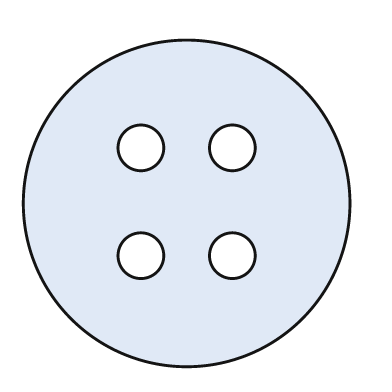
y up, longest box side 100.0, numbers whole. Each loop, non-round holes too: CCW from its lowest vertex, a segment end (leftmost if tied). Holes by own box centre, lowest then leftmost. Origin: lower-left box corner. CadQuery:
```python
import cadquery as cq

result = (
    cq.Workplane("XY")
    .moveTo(50.0, 50.0)
    .circle(50.0)
    .moveTo(36.0, 34.0)
    .circle(7.0)
    .moveTo(64.0, 34.0)
    .circle(7.0)
    .moveTo(36.0, 67.0)
    .circle(7.0)
    .moveTo(64.0, 67.0)
    .circle(7.0)
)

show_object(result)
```